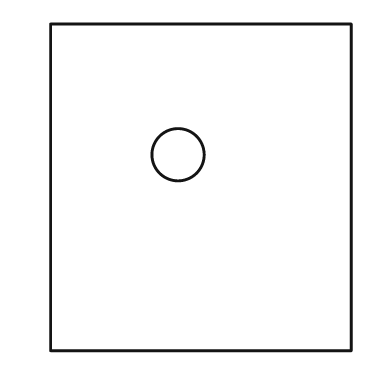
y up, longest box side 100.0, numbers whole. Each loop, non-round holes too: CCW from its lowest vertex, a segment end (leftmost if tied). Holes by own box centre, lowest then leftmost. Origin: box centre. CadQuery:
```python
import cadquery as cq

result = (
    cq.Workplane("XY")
    .moveTo(-46.0, -50.0)
    .lineTo(46.0, -50.0)
    .lineTo(46.0, 50.0)
    .lineTo(-46.0, 50.0)
    .close()
    .moveTo(-7.0, 10.0)
    .circle(8.0)
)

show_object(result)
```